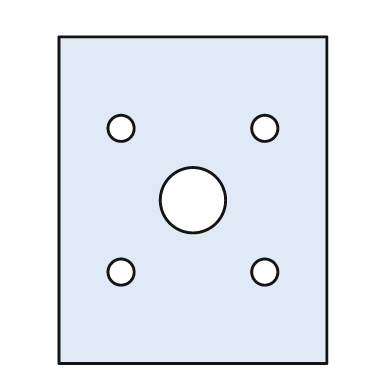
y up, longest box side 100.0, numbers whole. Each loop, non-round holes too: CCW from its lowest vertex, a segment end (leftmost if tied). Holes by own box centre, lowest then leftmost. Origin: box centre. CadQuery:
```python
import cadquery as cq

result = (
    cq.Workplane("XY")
    .moveTo(-41.0, -50.0)
    .lineTo(41.0, -50.0)
    .lineTo(41.0, 50.0)
    .lineTo(-41.0, 50.0)
    .close()
    .moveTo(-22.0, -22.0)
    .circle(4.0)
    .moveTo(22.0, -22.0)
    .circle(4.0)
    .moveTo(0.0, 0.0)
    .circle(10.0)
    .moveTo(-22.0, 22.0)
    .circle(4.0)
    .moveTo(22.0, 22.0)
    .circle(4.0)
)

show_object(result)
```